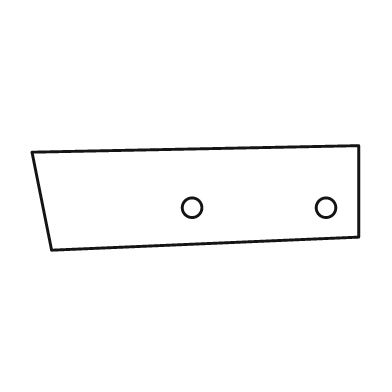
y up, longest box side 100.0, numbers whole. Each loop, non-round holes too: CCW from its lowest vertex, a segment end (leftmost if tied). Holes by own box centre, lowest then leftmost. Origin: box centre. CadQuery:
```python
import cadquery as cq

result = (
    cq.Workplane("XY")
    .moveTo(-44.0, -16.0)
    .lineTo(50.0, -12.0)
    .lineTo(50.0, 16.0)
    .lineTo(-50.0, 14.0)
    .close()
    .moveTo(-1.0, -3.0)
    .circle(3.0)
    .moveTo(40.0, -3.0)
    .circle(3.0)
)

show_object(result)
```